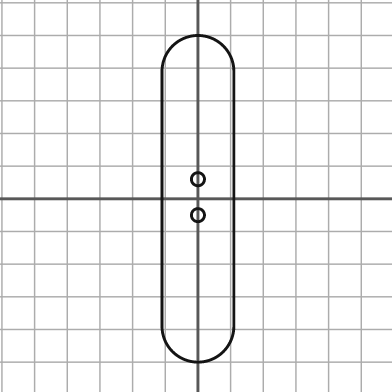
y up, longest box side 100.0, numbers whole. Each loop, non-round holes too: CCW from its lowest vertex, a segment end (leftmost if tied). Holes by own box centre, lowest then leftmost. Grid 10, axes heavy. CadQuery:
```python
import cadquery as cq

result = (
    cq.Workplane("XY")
    .moveTo(-11.0, -39.0)
    .threePointArc((0.0, -50.0), (11.0, -39.0))
    .lineTo(11.0, 39.0)
    .threePointArc((0.0, 50.0), (-11.0, 39.0))
    .close()
    .moveTo(0.0, -5.0)
    .circle(2.0)
    .moveTo(0.0, 6.0)
    .circle(2.0)
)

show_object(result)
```